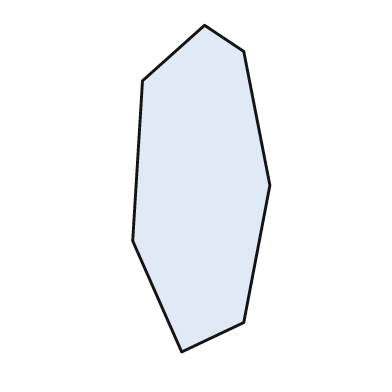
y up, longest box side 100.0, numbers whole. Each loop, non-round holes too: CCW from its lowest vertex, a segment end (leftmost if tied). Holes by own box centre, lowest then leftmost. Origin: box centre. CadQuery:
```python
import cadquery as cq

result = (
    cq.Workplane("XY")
    .moveTo(-6.0, -50.0)
    .lineTo(13.0, -41.0)
    .lineTo(21.0, 1.0)
    .lineTo(13.0, 42.0)
    .lineTo(1.0, 50.0)
    .lineTo(-18.0, 33.0)
    .lineTo(-21.0, -16.0)
    .close()
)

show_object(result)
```